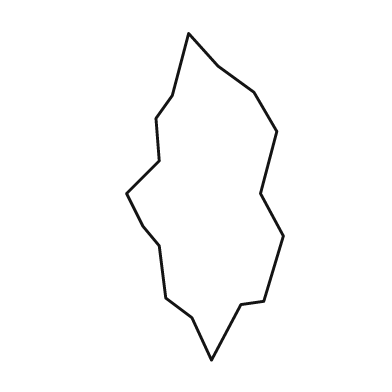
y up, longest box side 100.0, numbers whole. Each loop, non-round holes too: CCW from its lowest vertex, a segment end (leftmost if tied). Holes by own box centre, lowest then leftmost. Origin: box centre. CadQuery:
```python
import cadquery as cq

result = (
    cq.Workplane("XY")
    .moveTo(2.0, -50.0)
    .lineTo(11.0, -33.0)
    .lineTo(18.0, -32.0)
    .lineTo(24.0, -12.0)
    .lineTo(17.0, 1.0)
    .lineTo(22.0, 20.0)
    .lineTo(15.0, 32.0)
    .lineTo(4.0, 40.0)
    .lineTo(-5.0, 50.0)
    .lineTo(-10.0, 31.0)
    .lineTo(-15.0, 24.0)
    .lineTo(-14.0, 11.0)
    .lineTo(-24.0, 1.0)
    .lineTo(-19.0, -9.0)
    .lineTo(-14.0, -15.0)
    .lineTo(-12.0, -31.0)
    .lineTo(-4.0, -37.0)
    .close()
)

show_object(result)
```